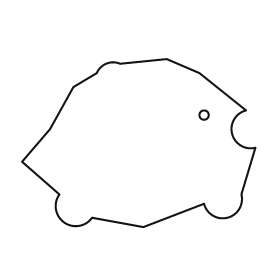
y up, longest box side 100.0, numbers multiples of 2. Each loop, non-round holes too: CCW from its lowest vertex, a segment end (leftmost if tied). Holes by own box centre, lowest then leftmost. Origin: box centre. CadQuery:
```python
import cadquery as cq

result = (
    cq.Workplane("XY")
    .moveTo(2.0, -36.0)
    .lineTo(28.0, -26.0)
    .threePointArc((38.0, -32.0), (44.0, -22.0))
    .lineTo(50.0, -2.0)
    .threePointArc((40.0, 4.0), (46.0, 14.0))
    .lineTo(26.0, 30.0)
    .lineTo(12.0, 36.0)
    .lineTo(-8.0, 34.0)
    .threePointArc((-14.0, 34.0), (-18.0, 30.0))
    .lineTo(-28.0, 24.0)
    .lineTo(-38.0, 6.0)
    .lineTo(-50.0, -8.0)
    .lineTo(-34.0, -22.0)
    .threePointArc((-32.0, -34.0), (-20.0, -32.0))
    .close()
    .moveTo(28.0, 12.0)
    .circle(2.0)
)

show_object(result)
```